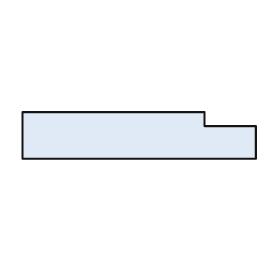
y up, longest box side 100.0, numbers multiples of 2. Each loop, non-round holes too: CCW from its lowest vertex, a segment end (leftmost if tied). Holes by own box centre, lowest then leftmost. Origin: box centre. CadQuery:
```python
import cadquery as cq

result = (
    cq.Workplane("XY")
    .moveTo(-50.0, -10.0)
    .lineTo(50.0, -10.0)
    .lineTo(50.0, 4.0)
    .lineTo(28.0, 4.0)
    .lineTo(28.0, 10.0)
    .lineTo(-50.0, 10.0)
    .close()
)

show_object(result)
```